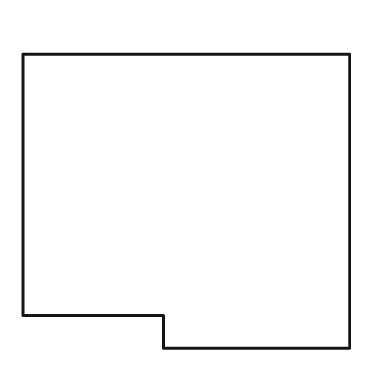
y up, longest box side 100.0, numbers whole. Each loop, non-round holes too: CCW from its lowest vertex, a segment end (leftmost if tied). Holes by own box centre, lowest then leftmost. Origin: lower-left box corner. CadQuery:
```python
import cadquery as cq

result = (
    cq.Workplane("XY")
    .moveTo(43.0, 0.0)
    .lineTo(100.0, 0.0)
    .lineTo(100.0, 90.0)
    .lineTo(0.0, 90.0)
    .lineTo(0.0, 10.0)
    .lineTo(43.0, 10.0)
    .close()
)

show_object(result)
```